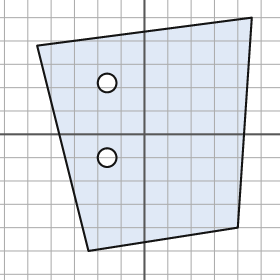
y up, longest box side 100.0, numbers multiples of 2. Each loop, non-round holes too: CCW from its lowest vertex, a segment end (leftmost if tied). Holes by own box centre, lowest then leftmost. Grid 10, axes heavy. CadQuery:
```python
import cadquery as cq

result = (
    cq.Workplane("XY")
    .moveTo(-24.0, -50.0)
    .lineTo(40.0, -40.0)
    .lineTo(46.0, 50.0)
    .lineTo(-46.0, 38.0)
    .close()
    .moveTo(-16.0, -10.0)
    .circle(4.0)
    .moveTo(-16.0, 22.0)
    .circle(4.0)
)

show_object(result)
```